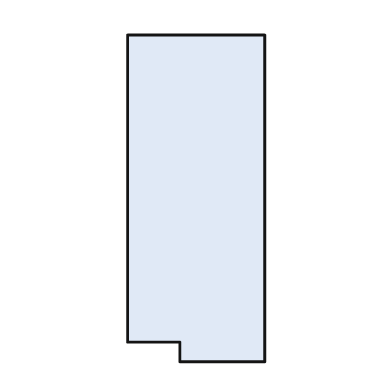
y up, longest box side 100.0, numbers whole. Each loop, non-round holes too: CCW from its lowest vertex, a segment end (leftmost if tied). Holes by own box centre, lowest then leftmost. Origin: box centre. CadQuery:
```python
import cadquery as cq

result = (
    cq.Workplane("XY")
    .moveTo(-5.0, -50.0)
    .lineTo(21.0, -50.0)
    .lineTo(21.0, 50.0)
    .lineTo(-21.0, 50.0)
    .lineTo(-21.0, -44.0)
    .lineTo(-5.0, -44.0)
    .close()
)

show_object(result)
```